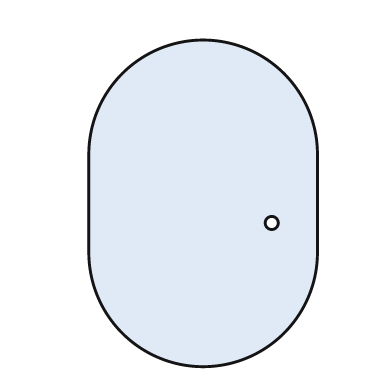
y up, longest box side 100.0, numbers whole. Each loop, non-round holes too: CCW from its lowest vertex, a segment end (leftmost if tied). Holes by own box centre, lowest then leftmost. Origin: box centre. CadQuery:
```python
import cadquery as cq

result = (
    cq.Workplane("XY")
    .moveTo(-35.0, -15.0)
    .threePointArc((0.0, -50.0), (35.0, -15.0))
    .lineTo(35.0, 15.0)
    .threePointArc((0.0, 50.0), (-35.0, 15.0))
    .close()
    .moveTo(21.0, -6.0)
    .circle(2.0)
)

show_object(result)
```